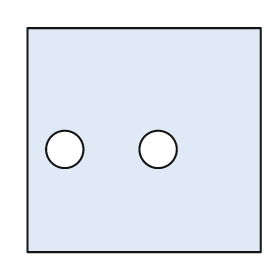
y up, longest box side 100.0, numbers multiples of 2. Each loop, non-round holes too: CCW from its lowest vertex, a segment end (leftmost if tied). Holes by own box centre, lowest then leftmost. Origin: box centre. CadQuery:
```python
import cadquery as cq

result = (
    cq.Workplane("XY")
    .moveTo(-50.0, -48.0)
    .lineTo(50.0, -48.0)
    .lineTo(50.0, 48.0)
    .lineTo(-50.0, 48.0)
    .close()
    .moveTo(-34.0, -4.0)
    .circle(8.0)
    .moveTo(6.0, -4.0)
    .circle(8.0)
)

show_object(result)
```